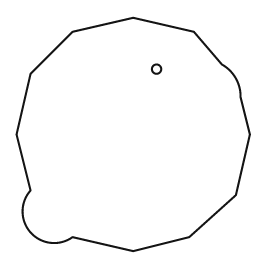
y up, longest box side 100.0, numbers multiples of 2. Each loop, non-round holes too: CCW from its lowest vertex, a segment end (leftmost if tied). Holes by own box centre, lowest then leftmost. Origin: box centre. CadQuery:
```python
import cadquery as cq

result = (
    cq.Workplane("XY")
    .moveTo(0.0, -50.0)
    .lineTo(24.0, -44.0)
    .lineTo(44.0, -26.0)
    .lineTo(50.0, 0.0)
    .lineTo(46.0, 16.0)
    .threePointArc((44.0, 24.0), (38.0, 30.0))
    .lineTo(26.0, 44.0)
    .lineTo(0.0, 50.0)
    .lineTo(-26.0, 44.0)
    .lineTo(-44.0, 26.0)
    .lineTo(-50.0, 0.0)
    .lineTo(-44.0, -24.0)
    .threePointArc((-44.0, -42.0), (-26.0, -44.0))
    .close()
    .moveTo(10.0, 28.0)
    .circle(2.0)
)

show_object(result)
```